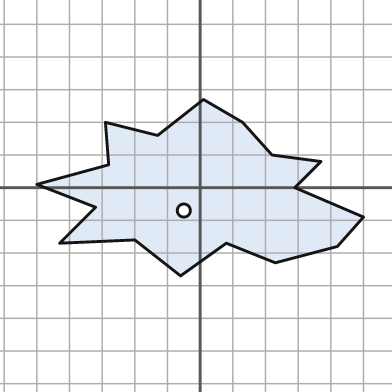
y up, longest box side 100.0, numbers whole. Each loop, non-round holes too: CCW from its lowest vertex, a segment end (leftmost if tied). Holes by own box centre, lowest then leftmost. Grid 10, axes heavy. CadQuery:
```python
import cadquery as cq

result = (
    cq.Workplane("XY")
    .moveTo(-6.0, -27.0)
    .lineTo(8.0, -17.0)
    .lineTo(23.0, -23.0)
    .lineTo(42.0, -18.0)
    .lineTo(50.0, -9.0)
    .lineTo(29.0, 0.0)
    .lineTo(37.0, 8.0)
    .lineTo(22.0, 10.0)
    .lineTo(13.0, 20.0)
    .lineTo(1.0, 27.0)
    .lineTo(-13.0, 16.0)
    .lineTo(-29.0, 20.0)
    .lineTo(-28.0, 7.0)
    .lineTo(-50.0, 1.0)
    .lineTo(-32.0, -6.0)
    .lineTo(-43.0, -17.0)
    .lineTo(-20.0, -16.0)
    .close()
    .moveTo(-5.0, -7.0)
    .circle(2.0)
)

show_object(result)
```